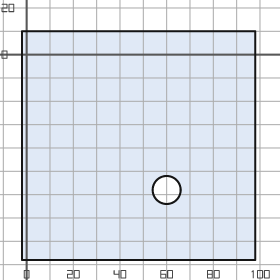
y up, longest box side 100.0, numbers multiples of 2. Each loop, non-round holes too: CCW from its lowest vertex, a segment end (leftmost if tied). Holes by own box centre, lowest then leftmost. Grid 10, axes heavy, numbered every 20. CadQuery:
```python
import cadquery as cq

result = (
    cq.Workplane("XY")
    .moveTo(-2.0, -88.0)
    .lineTo(98.0, -88.0)
    .lineTo(98.0, 10.0)
    .lineTo(-2.0, 10.0)
    .close()
    .moveTo(60.0, -58.0)
    .circle(6.0)
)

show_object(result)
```